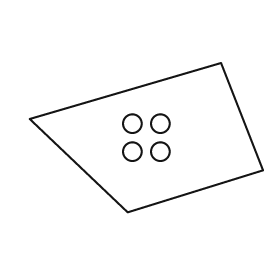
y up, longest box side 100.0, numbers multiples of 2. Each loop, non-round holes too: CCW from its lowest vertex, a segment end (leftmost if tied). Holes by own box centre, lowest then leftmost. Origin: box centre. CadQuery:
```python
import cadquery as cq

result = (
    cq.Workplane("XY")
    .moveTo(-8.0, -32.0)
    .lineTo(50.0, -14.0)
    .lineTo(32.0, 32.0)
    .lineTo(-50.0, 8.0)
    .close()
    .moveTo(-6.0, -6.0)
    .circle(4.0)
    .moveTo(6.0, -6.0)
    .circle(4.0)
    .moveTo(-6.0, 6.0)
    .circle(4.0)
    .moveTo(6.0, 6.0)
    .circle(4.0)
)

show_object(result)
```